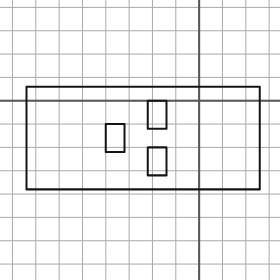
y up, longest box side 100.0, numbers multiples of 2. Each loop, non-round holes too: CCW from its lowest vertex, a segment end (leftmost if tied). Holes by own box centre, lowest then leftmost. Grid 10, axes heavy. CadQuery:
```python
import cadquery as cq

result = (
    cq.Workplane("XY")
    .moveTo(-74.0, -38.0)
    .lineTo(26.0, -38.0)
    .lineTo(26.0, 6.0)
    .lineTo(-74.0, 6.0)
    .close()
    .moveTo(-22.0, -32.0)
    .lineTo(-14.0, -32.0)
    .lineTo(-14.0, -20.0)
    .lineTo(-22.0, -20.0)
    .close()
    .moveTo(-40.0, -22.0)
    .lineTo(-32.0, -22.0)
    .lineTo(-32.0, -10.0)
    .lineTo(-40.0, -10.0)
    .close()
    .moveTo(-22.0, -12.0)
    .lineTo(-14.0, -12.0)
    .lineTo(-14.0, 0.0)
    .lineTo(-22.0, 0.0)
    .close()
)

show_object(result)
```